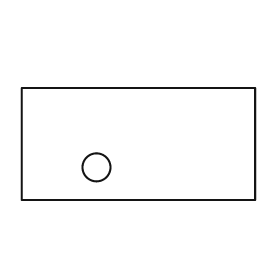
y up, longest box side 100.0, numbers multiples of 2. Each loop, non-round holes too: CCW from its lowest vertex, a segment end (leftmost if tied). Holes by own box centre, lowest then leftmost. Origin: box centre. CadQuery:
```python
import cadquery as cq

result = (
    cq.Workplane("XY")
    .moveTo(-50.0, -24.0)
    .lineTo(50.0, -24.0)
    .lineTo(50.0, 24.0)
    .lineTo(-50.0, 24.0)
    .close()
    .moveTo(-18.0, -10.0)
    .circle(6.0)
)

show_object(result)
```